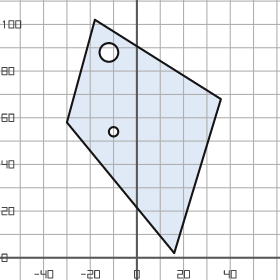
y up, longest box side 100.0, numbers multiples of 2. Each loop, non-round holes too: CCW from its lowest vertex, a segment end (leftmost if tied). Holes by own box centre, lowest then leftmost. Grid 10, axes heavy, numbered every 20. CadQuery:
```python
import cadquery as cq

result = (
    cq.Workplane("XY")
    .moveTo(16.0, 2.0)
    .lineTo(36.0, 68.0)
    .lineTo(-18.0, 102.0)
    .lineTo(-30.0, 58.0)
    .close()
    .moveTo(-10.0, 54.0)
    .circle(2.0)
    .moveTo(-12.0, 88.0)
    .circle(4.0)
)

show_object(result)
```